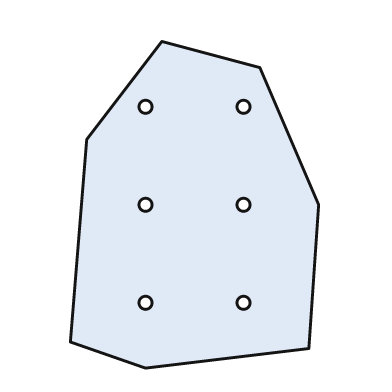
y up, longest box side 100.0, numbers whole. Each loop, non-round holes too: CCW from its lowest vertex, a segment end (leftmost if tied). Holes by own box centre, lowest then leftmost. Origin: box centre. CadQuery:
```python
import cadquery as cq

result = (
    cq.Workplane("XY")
    .moveTo(-15.0, -50.0)
    .lineTo(35.0, -44.0)
    .lineTo(38.0, 0.0)
    .lineTo(20.0, 42.0)
    .lineTo(-10.0, 50.0)
    .lineTo(-33.0, 20.0)
    .lineTo(-38.0, -42.0)
    .close()
    .moveTo(-15.0, -30.0)
    .circle(2.0)
    .moveTo(15.0, -30.0)
    .circle(2.0)
    .moveTo(-15.0, 0.0)
    .circle(2.0)
    .moveTo(15.0, 0.0)
    .circle(2.0)
    .moveTo(-15.0, 30.0)
    .circle(2.0)
    .moveTo(15.0, 30.0)
    .circle(2.0)
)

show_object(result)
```